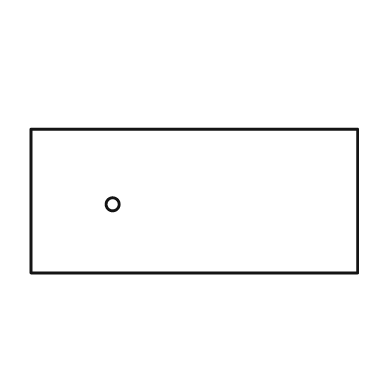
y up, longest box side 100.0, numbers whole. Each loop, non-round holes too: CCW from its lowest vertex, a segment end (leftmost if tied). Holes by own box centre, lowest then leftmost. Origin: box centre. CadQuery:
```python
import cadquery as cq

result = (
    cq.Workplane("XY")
    .moveTo(-50.0, -22.0)
    .lineTo(50.0, -22.0)
    .lineTo(50.0, 22.0)
    .lineTo(-50.0, 22.0)
    .close()
    .moveTo(-25.0, -1.0)
    .circle(2.0)
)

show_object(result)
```